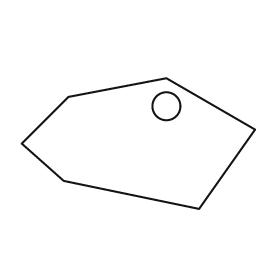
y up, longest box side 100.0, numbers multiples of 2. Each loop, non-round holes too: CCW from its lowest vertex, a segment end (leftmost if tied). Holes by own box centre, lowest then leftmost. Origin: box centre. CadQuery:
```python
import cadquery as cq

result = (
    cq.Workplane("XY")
    .moveTo(26.0, -28.0)
    .lineTo(50.0, 6.0)
    .lineTo(12.0, 28.0)
    .lineTo(-30.0, 20.0)
    .lineTo(-50.0, 0.0)
    .lineTo(-32.0, -16.0)
    .close()
    .moveTo(12.0, 16.0)
    .circle(6.0)
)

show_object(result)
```